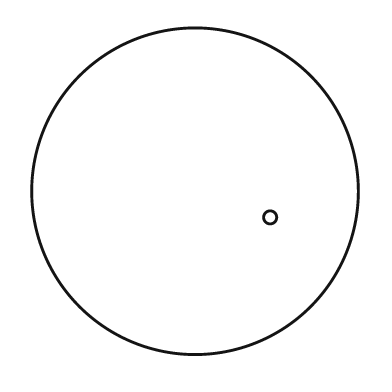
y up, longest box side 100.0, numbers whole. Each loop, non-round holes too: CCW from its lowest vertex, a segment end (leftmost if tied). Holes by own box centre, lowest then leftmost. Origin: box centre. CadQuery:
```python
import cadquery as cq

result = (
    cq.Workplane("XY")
    .moveTo(0.0, 0.0)
    .circle(50.0)
    .moveTo(23.0, -8.0)
    .circle(2.0)
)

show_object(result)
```